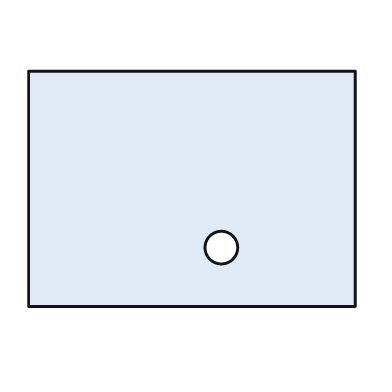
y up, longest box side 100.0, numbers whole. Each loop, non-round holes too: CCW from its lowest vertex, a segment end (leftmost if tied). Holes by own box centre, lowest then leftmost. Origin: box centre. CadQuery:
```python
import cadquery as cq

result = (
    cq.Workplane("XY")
    .moveTo(-50.0, -36.0)
    .lineTo(50.0, -36.0)
    .lineTo(50.0, 36.0)
    .lineTo(-50.0, 36.0)
    .close()
    .moveTo(9.0, -18.0)
    .circle(5.0)
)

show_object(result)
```